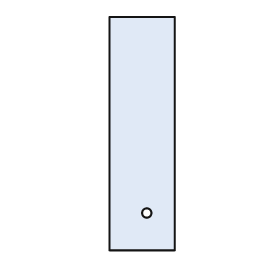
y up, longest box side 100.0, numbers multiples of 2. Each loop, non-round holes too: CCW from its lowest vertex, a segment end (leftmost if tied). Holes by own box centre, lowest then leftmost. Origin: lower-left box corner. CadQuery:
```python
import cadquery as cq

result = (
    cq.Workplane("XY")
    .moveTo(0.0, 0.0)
    .lineTo(28.0, 0.0)
    .lineTo(28.0, 100.0)
    .lineTo(0.0, 100.0)
    .close()
    .moveTo(16.0, 16.0)
    .circle(2.0)
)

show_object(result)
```